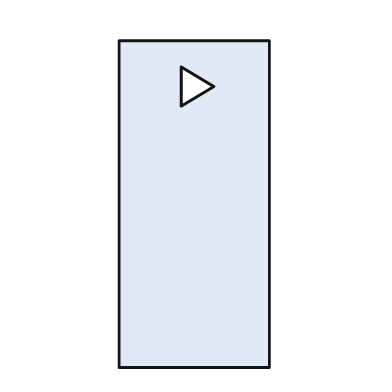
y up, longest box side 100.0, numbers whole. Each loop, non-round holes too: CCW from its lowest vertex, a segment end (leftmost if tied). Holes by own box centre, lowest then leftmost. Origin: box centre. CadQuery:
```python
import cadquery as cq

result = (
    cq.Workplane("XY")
    .moveTo(-23.0, -50.0)
    .lineTo(23.0, -50.0)
    .lineTo(23.0, 50.0)
    .lineTo(-23.0, 50.0)
    .close()
    .moveTo(-4.0, 30.0)
    .lineTo(6.0, 36.0)
    .lineTo(-4.0, 42.0)
    .close()
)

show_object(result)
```